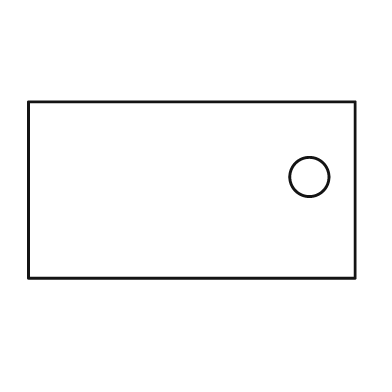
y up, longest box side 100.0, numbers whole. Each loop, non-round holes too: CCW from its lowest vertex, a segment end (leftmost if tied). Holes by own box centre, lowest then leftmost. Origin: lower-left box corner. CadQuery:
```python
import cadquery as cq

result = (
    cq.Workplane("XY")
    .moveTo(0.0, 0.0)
    .lineTo(100.0, 0.0)
    .lineTo(100.0, 54.0)
    .lineTo(0.0, 54.0)
    .close()
    .moveTo(86.0, 31.0)
    .circle(6.0)
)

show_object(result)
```